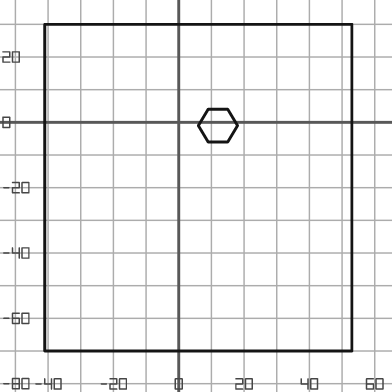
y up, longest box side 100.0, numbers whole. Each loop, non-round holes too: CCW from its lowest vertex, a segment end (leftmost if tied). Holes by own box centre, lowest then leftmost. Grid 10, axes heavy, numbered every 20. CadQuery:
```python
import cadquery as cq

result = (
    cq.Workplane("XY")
    .moveTo(-41.0, -70.0)
    .lineTo(53.0, -70.0)
    .lineTo(53.0, 30.0)
    .lineTo(-41.0, 30.0)
    .close()
    .moveTo(9.0, -6.0)
    .lineTo(15.0, -6.0)
    .lineTo(18.0, -1.0)
    .lineTo(15.0, 4.0)
    .lineTo(9.0, 4.0)
    .lineTo(6.0, -1.0)
    .close()
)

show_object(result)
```